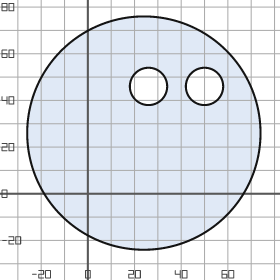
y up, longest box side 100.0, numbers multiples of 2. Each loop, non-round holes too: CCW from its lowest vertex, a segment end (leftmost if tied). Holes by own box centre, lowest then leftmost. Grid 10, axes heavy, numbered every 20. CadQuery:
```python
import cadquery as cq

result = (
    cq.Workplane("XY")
    .moveTo(24.0, 26.0)
    .circle(50.0)
    .moveTo(26.0, 46.0)
    .circle(8.0)
    .moveTo(50.0, 46.0)
    .circle(8.0)
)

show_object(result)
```